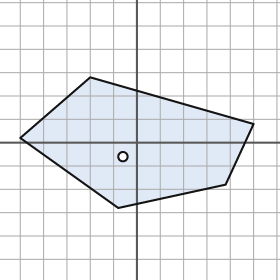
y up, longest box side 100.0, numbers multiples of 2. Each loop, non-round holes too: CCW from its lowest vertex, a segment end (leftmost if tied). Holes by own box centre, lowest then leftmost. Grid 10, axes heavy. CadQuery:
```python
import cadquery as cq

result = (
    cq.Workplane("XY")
    .moveTo(-8.0, -28.0)
    .lineTo(38.0, -18.0)
    .lineTo(50.0, 8.0)
    .lineTo(-20.0, 28.0)
    .lineTo(-50.0, 2.0)
    .close()
    .moveTo(-6.0, -6.0)
    .circle(2.0)
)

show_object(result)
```